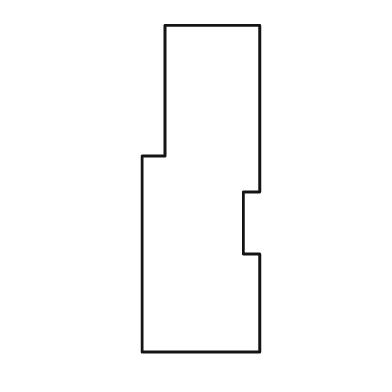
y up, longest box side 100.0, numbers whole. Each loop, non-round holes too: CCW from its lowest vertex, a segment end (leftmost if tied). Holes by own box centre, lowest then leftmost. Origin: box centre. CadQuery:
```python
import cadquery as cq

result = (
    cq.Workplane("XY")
    .moveTo(-18.0, -50.0)
    .lineTo(18.0, -50.0)
    .lineTo(18.0, -20.0)
    .lineTo(13.0, -20.0)
    .lineTo(13.0, -1.0)
    .lineTo(18.0, -1.0)
    .lineTo(18.0, 50.0)
    .lineTo(-11.0, 50.0)
    .lineTo(-11.0, 10.0)
    .lineTo(-18.0, 10.0)
    .close()
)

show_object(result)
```